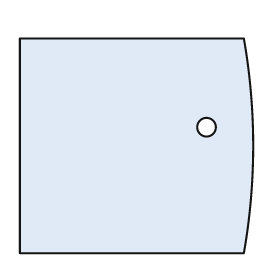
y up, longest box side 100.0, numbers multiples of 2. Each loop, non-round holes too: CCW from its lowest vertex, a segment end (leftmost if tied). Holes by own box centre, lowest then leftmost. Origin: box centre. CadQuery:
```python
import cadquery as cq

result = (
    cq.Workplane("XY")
    .moveTo(-50.0, -46.0)
    .lineTo(46.0, -46.0)
    .threePointArc((50.0, 0.0), (46.0, 46.0))
    .lineTo(-50.0, 46.0)
    .close()
    .moveTo(30.0, 8.0)
    .circle(4.0)
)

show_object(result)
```